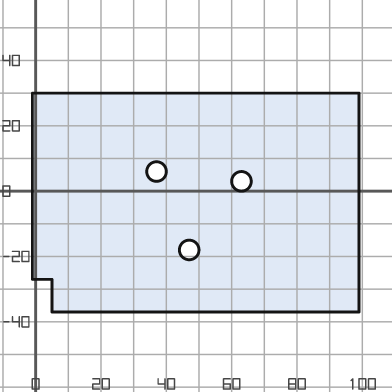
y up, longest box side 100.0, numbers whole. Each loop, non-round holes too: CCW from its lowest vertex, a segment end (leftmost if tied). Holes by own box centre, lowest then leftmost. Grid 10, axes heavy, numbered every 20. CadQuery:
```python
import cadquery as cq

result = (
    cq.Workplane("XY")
    .moveTo(5.0, -37.0)
    .lineTo(99.0, -37.0)
    .lineTo(99.0, 30.0)
    .lineTo(-1.0, 30.0)
    .lineTo(-1.0, -27.0)
    .lineTo(5.0, -27.0)
    .close()
    .moveTo(47.0, -18.0)
    .circle(3.0)
    .moveTo(63.0, 3.0)
    .circle(3.0)
    .moveTo(37.0, 6.0)
    .circle(3.0)
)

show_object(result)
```